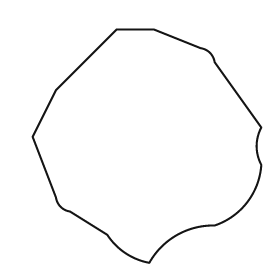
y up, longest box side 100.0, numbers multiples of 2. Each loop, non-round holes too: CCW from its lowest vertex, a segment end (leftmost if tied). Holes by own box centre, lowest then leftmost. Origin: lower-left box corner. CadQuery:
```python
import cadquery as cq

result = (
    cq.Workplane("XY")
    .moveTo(50.0, 0.0)
    .threePointArc((62.0, 12.0), (78.0, 16.0))
    .threePointArc((92.0, 26.0), (98.0, 42.0))
    .threePointArc((96.0, 50.0), (98.0, 58.0))
    .lineTo(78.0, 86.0)
    .threePointArc((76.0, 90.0), (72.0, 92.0))
    .lineTo(52.0, 100.0)
    .lineTo(36.0, 100.0)
    .lineTo(10.0, 74.0)
    .lineTo(0.0, 54.0)
    .lineTo(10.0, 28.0)
    .threePointArc((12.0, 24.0), (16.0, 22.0))
    .lineTo(32.0, 12.0)
    .threePointArc((40.0, 4.0), (50.0, 0.0))
    .close()
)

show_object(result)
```